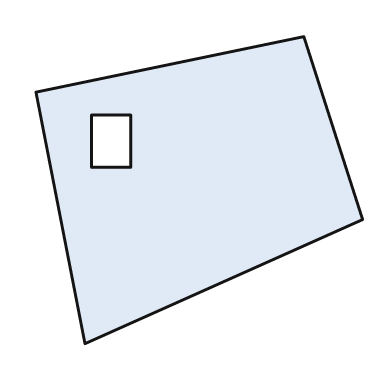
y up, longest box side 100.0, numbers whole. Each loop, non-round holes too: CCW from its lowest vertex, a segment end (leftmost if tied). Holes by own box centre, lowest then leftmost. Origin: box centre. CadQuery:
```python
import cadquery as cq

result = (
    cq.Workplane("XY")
    .moveTo(-35.0, -47.0)
    .lineTo(50.0, -9.0)
    .lineTo(32.0, 47.0)
    .lineTo(-50.0, 30.0)
    .close()
    .moveTo(-33.0, 7.0)
    .lineTo(-21.0, 7.0)
    .lineTo(-21.0, 23.0)
    .lineTo(-33.0, 23.0)
    .close()
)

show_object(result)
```